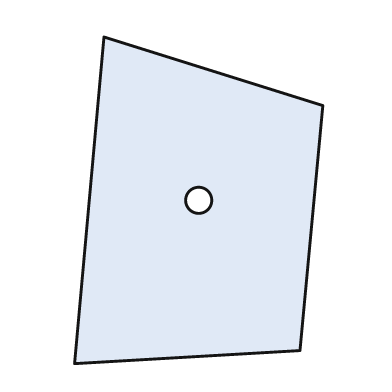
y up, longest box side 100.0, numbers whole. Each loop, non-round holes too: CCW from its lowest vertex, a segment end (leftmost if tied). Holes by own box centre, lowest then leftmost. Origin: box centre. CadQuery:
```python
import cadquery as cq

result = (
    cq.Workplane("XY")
    .moveTo(-38.0, -50.0)
    .lineTo(31.0, -46.0)
    .lineTo(38.0, 29.0)
    .lineTo(-29.0, 50.0)
    .close()
    .moveTo(0.0, 0.0)
    .circle(4.0)
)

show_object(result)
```